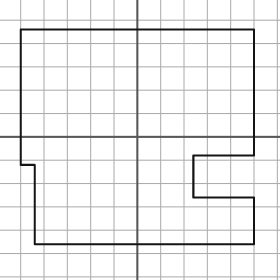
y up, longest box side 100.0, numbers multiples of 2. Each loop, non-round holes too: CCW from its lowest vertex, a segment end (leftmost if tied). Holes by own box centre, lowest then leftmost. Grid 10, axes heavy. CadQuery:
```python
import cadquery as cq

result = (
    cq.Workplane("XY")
    .moveTo(-44.0, -46.0)
    .lineTo(50.0, -46.0)
    .lineTo(50.0, -26.0)
    .lineTo(24.0, -26.0)
    .lineTo(24.0, -8.0)
    .lineTo(50.0, -8.0)
    .lineTo(50.0, 46.0)
    .lineTo(-50.0, 46.0)
    .lineTo(-50.0, -12.0)
    .lineTo(-44.0, -12.0)
    .close()
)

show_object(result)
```